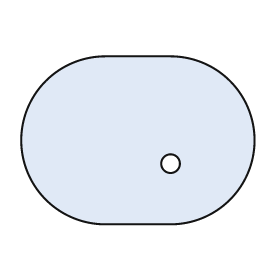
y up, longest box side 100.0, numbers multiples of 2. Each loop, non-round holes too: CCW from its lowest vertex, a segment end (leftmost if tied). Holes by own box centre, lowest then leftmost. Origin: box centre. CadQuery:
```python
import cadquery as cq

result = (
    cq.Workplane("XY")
    .moveTo(-14.0, -36.0)
    .lineTo(14.0, -36.0)
    .threePointArc((50.0, 0.0), (14.0, 36.0))
    .lineTo(-14.0, 36.0)
    .threePointArc((-50.0, 0.0), (-14.0, -36.0))
    .close()
    .moveTo(14.0, -10.0)
    .circle(4.0)
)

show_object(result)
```